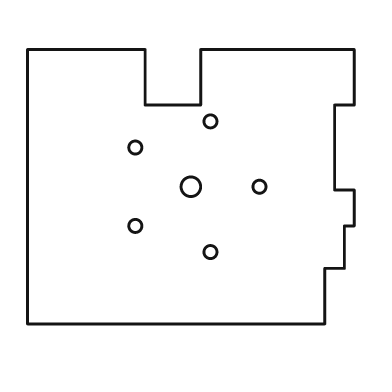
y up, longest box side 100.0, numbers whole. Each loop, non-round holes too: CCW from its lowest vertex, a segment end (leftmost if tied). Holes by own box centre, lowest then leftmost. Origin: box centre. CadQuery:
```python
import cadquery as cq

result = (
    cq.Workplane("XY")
    .moveTo(-50.0, -42.0)
    .lineTo(41.0, -42.0)
    .lineTo(41.0, -25.0)
    .lineTo(47.0, -25.0)
    .lineTo(47.0, -12.0)
    .lineTo(50.0, -12.0)
    .lineTo(50.0, -1.0)
    .lineTo(44.0, -1.0)
    .lineTo(44.0, 25.0)
    .lineTo(50.0, 25.0)
    .lineTo(50.0, 42.0)
    .lineTo(3.0, 42.0)
    .lineTo(3.0, 25.0)
    .lineTo(-14.0, 25.0)
    .lineTo(-14.0, 42.0)
    .lineTo(-50.0, 42.0)
    .close()
    .moveTo(6.0, -20.0)
    .circle(2.0)
    .moveTo(-17.0, -12.0)
    .circle(2.0)
    .moveTo(0.0, 0.0)
    .circle(3.0)
    .moveTo(21.0, 0.0)
    .circle(2.0)
    .moveTo(-17.0, 12.0)
    .circle(2.0)
    .moveTo(6.0, 20.0)
    .circle(2.0)
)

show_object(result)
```